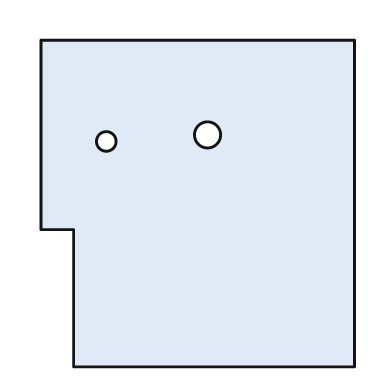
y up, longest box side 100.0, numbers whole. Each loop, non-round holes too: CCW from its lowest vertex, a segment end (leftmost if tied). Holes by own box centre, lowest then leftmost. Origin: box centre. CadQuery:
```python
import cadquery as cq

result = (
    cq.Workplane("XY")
    .moveTo(-38.0, -50.0)
    .lineTo(48.0, -50.0)
    .lineTo(48.0, 50.0)
    .lineTo(-48.0, 50.0)
    .lineTo(-48.0, -8.0)
    .lineTo(-38.0, -8.0)
    .close()
    .moveTo(-28.0, 19.0)
    .circle(3.0)
    .moveTo(3.0, 21.0)
    .circle(4.0)
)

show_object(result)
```